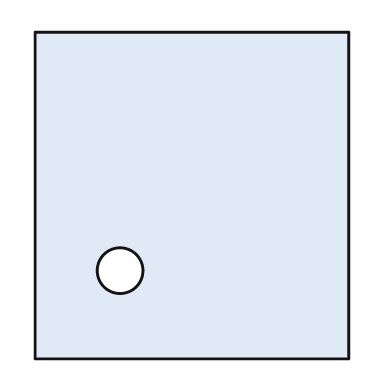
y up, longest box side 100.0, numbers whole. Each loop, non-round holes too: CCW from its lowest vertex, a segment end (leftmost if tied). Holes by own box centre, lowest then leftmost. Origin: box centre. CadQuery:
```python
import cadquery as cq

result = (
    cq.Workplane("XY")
    .moveTo(-48.0, -50.0)
    .lineTo(48.0, -50.0)
    .lineTo(48.0, 50.0)
    .lineTo(-48.0, 50.0)
    .close()
    .moveTo(-22.0, -23.0)
    .circle(7.0)
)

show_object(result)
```